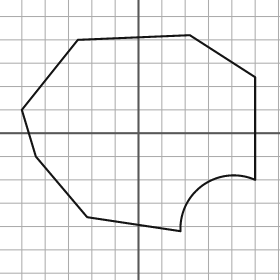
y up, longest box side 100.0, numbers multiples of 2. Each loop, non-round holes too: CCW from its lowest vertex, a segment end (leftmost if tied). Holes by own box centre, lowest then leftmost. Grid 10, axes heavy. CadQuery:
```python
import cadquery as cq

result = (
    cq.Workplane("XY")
    .moveTo(18.0, -42.0)
    .threePointArc((28.0, -22.0), (50.0, -20.0))
    .lineTo(50.0, 24.0)
    .lineTo(22.0, 42.0)
    .lineTo(-26.0, 40.0)
    .lineTo(-50.0, 10.0)
    .lineTo(-44.0, -10.0)
    .lineTo(-22.0, -36.0)
    .close()
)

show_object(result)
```